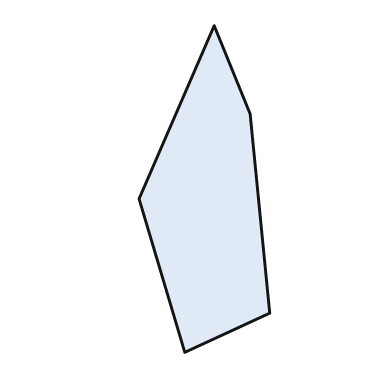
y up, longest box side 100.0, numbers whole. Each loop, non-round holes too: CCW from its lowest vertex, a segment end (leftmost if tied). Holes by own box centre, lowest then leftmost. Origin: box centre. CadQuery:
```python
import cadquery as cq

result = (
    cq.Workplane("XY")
    .moveTo(-6.0, -50.0)
    .lineTo(20.0, -38.0)
    .lineTo(14.0, 23.0)
    .lineTo(3.0, 50.0)
    .lineTo(-20.0, -3.0)
    .close()
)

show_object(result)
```